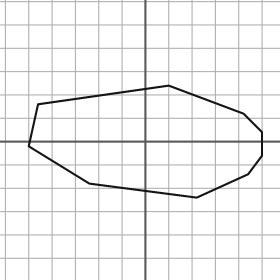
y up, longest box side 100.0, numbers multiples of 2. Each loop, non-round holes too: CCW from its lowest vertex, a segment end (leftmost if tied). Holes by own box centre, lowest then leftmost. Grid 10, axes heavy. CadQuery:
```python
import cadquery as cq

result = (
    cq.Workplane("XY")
    .moveTo(22.0, -24.0)
    .lineTo(44.0, -14.0)
    .lineTo(50.0, -6.0)
    .lineTo(50.0, 4.0)
    .lineTo(42.0, 12.0)
    .lineTo(10.0, 24.0)
    .lineTo(-46.0, 16.0)
    .lineTo(-50.0, -2.0)
    .lineTo(-24.0, -18.0)
    .close()
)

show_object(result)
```